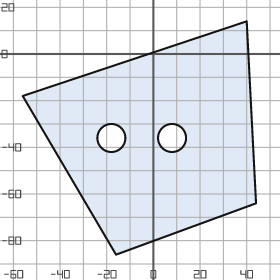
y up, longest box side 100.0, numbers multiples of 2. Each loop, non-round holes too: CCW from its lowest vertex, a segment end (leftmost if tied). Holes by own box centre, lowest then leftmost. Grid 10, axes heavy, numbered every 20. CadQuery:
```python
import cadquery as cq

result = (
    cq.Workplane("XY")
    .moveTo(-16.0, -86.0)
    .lineTo(44.0, -64.0)
    .lineTo(40.0, 14.0)
    .lineTo(-56.0, -18.0)
    .close()
    .moveTo(-18.0, -36.0)
    .circle(6.0)
    .moveTo(8.0, -36.0)
    .circle(6.0)
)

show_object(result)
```